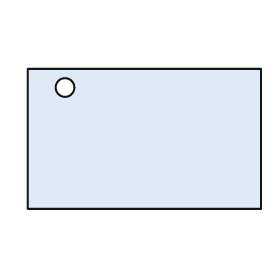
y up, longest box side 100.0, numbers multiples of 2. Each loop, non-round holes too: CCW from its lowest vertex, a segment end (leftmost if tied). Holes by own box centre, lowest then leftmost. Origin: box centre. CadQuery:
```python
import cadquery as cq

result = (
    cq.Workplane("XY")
    .moveTo(-50.0, -30.0)
    .lineTo(50.0, -30.0)
    .lineTo(50.0, 30.0)
    .lineTo(-50.0, 30.0)
    .close()
    .moveTo(-34.0, 22.0)
    .circle(4.0)
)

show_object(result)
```